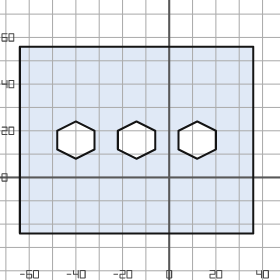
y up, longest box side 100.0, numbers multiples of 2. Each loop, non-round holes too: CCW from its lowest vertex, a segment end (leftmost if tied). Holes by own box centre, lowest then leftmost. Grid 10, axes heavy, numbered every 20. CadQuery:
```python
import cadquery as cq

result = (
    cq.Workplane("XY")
    .moveTo(-64.0, -24.0)
    .lineTo(36.0, -24.0)
    .lineTo(36.0, 56.0)
    .lineTo(-64.0, 56.0)
    .close()
    .moveTo(-40.0, 8.0)
    .lineTo(-32.0, 12.0)
    .lineTo(-32.0, 20.0)
    .lineTo(-40.0, 24.0)
    .lineTo(-48.0, 20.0)
    .lineTo(-48.0, 12.0)
    .close()
    .moveTo(-14.0, 8.0)
    .lineTo(-6.0, 12.0)
    .lineTo(-6.0, 20.0)
    .lineTo(-14.0, 24.0)
    .lineTo(-22.0, 20.0)
    .lineTo(-22.0, 12.0)
    .close()
    .moveTo(12.0, 8.0)
    .lineTo(20.0, 12.0)
    .lineTo(20.0, 20.0)
    .lineTo(12.0, 24.0)
    .lineTo(4.0, 20.0)
    .lineTo(4.0, 12.0)
    .close()
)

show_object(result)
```